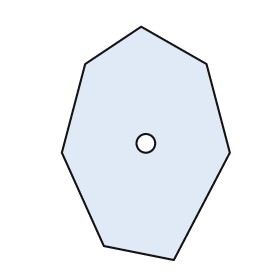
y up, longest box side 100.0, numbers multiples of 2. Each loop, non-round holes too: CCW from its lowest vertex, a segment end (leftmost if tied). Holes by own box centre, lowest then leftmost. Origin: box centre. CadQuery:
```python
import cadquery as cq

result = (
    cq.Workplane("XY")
    .moveTo(12.0, -50.0)
    .lineTo(36.0, -4.0)
    .lineTo(26.0, 34.0)
    .lineTo(-2.0, 50.0)
    .lineTo(-26.0, 34.0)
    .lineTo(-36.0, -4.0)
    .lineTo(-18.0, -44.0)
    .close()
    .moveTo(0.0, 0.0)
    .circle(4.0)
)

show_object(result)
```